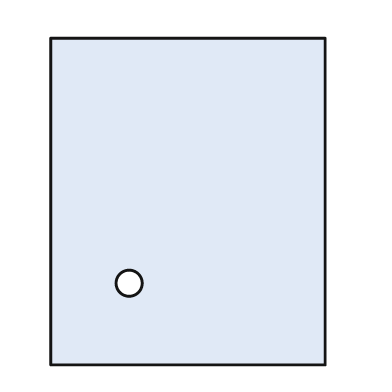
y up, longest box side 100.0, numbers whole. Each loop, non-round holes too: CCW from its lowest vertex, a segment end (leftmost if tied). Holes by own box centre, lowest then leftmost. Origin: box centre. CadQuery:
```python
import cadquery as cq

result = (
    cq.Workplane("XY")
    .moveTo(-42.0, -50.0)
    .lineTo(42.0, -50.0)
    .lineTo(42.0, 50.0)
    .lineTo(-42.0, 50.0)
    .close()
    .moveTo(-18.0, -25.0)
    .circle(4.0)
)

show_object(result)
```